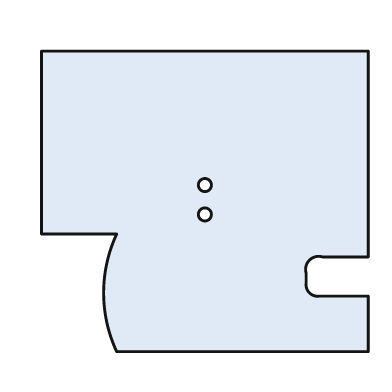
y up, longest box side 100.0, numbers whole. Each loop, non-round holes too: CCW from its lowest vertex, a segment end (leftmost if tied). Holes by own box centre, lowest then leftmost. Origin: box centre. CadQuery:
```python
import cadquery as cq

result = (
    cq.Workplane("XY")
    .moveTo(-27.0, -46.0)
    .lineTo(50.0, -46.0)
    .lineTo(50.0, -29.0)
    .lineTo(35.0, -29.0)
    .threePointArc((32.0, -28.0), (31.0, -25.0))
    .lineTo(31.0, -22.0)
    .threePointArc((32.0, -18.0), (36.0, -17.0))
    .lineTo(50.0, -17.0)
    .lineTo(50.0, 46.0)
    .lineTo(-50.0, 46.0)
    .lineTo(-50.0, -10.0)
    .lineTo(-27.0, -10.0)
    .threePointArc((-31.0, -28.0), (-27.0, -46.0))
    .close()
    .moveTo(0.0, -4.0)
    .circle(2.0)
    .moveTo(0.0, 5.0)
    .circle(2.0)
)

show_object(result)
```